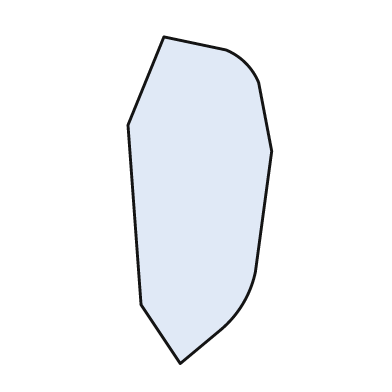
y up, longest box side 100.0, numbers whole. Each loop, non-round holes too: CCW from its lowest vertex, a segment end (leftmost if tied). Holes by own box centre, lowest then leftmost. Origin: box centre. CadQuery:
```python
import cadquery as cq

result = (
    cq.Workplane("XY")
    .moveTo(-6.0, -50.0)
    .lineTo(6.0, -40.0)
    .threePointArc((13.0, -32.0), (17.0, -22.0))
    .lineTo(22.0, 15.0)
    .lineTo(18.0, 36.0)
    .threePointArc((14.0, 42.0), (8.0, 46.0))
    .lineTo(-11.0, 50.0)
    .lineTo(-22.0, 23.0)
    .lineTo(-18.0, -32.0)
    .close()
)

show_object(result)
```